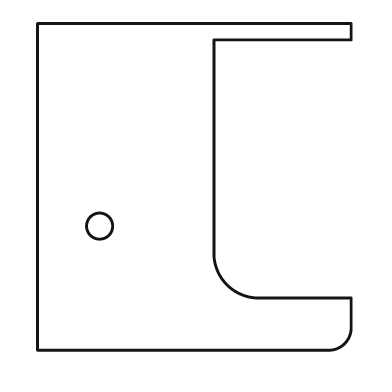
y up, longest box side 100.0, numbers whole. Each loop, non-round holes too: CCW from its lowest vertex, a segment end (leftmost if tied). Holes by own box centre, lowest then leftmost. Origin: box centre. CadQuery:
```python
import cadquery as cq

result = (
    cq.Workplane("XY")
    .moveTo(-48.0, -50.0)
    .lineTo(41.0, -50.0)
    .threePointArc((46.0, -48.0), (48.0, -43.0))
    .lineTo(48.0, -34.0)
    .lineTo(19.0, -34.0)
    .threePointArc((10.0, -30.0), (6.0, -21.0))
    .lineTo(6.0, 45.0)
    .lineTo(48.0, 45.0)
    .lineTo(48.0, 50.0)
    .lineTo(-48.0, 50.0)
    .close()
    .moveTo(-29.0, -12.0)
    .circle(4.0)
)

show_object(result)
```